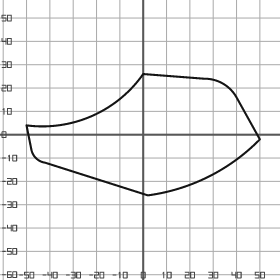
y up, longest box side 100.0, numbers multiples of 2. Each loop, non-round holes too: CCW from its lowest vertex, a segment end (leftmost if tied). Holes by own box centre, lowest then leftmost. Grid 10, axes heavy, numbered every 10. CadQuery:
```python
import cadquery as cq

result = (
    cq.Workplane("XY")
    .moveTo(2.0, -26.0)
    .threePointArc((28.0, -18.0), (50.0, -2.0))
    .lineTo(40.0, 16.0)
    .threePointArc((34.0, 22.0), (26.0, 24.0))
    .lineTo(0.0, 26.0)
    .threePointArc((-22.0, 8.0), (-50.0, 4.0))
    .lineTo(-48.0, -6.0)
    .threePointArc((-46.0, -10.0), (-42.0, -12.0))
    .close()
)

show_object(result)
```